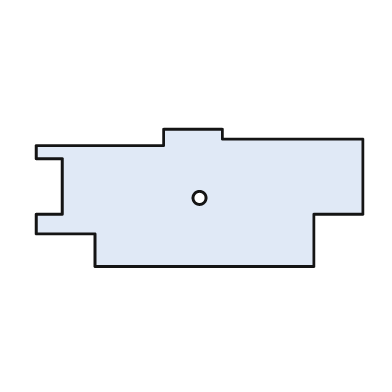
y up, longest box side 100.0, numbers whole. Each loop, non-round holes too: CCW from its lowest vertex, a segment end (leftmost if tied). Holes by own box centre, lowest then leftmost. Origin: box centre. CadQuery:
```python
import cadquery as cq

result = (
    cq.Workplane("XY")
    .moveTo(-32.0, -21.0)
    .lineTo(35.0, -21.0)
    .lineTo(35.0, -5.0)
    .lineTo(50.0, -5.0)
    .lineTo(50.0, 18.0)
    .lineTo(7.0, 18.0)
    .lineTo(7.0, 21.0)
    .lineTo(-11.0, 21.0)
    .lineTo(-11.0, 16.0)
    .lineTo(-50.0, 16.0)
    .lineTo(-50.0, 12.0)
    .lineTo(-42.0, 12.0)
    .lineTo(-42.0, -5.0)
    .lineTo(-50.0, -5.0)
    .lineTo(-50.0, -11.0)
    .lineTo(-32.0, -11.0)
    .close()
    .moveTo(0.0, 0.0)
    .circle(2.0)
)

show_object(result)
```